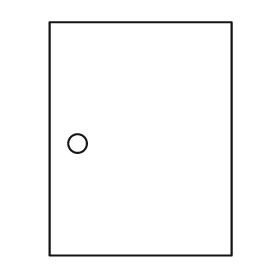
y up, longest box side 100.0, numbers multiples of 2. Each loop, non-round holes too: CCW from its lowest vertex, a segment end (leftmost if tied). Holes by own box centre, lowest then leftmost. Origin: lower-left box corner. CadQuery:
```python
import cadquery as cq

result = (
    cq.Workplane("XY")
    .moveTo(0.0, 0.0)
    .lineTo(78.0, 0.0)
    .lineTo(78.0, 100.0)
    .lineTo(0.0, 100.0)
    .close()
    .moveTo(12.0, 48.0)
    .circle(4.0)
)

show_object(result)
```